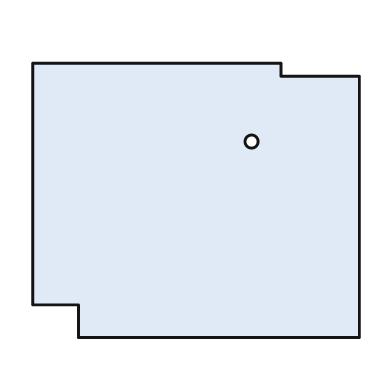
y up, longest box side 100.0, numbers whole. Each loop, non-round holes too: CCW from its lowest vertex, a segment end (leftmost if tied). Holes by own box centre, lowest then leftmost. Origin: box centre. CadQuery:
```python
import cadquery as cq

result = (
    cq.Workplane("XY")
    .moveTo(-36.0, -42.0)
    .lineTo(50.0, -42.0)
    .lineTo(50.0, 38.0)
    .lineTo(26.0, 38.0)
    .lineTo(26.0, 42.0)
    .lineTo(-50.0, 42.0)
    .lineTo(-50.0, -32.0)
    .lineTo(-36.0, -32.0)
    .close()
    .moveTo(17.0, 18.0)
    .circle(2.0)
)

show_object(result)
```